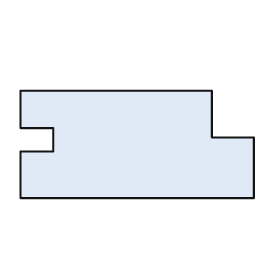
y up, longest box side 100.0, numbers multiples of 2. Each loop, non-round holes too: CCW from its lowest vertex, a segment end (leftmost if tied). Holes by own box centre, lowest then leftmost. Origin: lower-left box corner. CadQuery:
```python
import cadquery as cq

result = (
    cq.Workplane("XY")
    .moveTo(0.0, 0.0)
    .lineTo(100.0, 0.0)
    .lineTo(100.0, 26.0)
    .lineTo(82.0, 26.0)
    .lineTo(82.0, 46.0)
    .lineTo(0.0, 46.0)
    .lineTo(0.0, 30.0)
    .lineTo(14.0, 30.0)
    .lineTo(14.0, 20.0)
    .lineTo(0.0, 20.0)
    .close()
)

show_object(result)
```